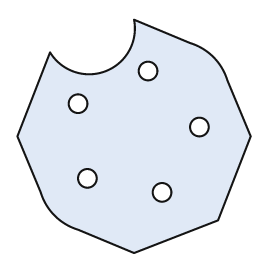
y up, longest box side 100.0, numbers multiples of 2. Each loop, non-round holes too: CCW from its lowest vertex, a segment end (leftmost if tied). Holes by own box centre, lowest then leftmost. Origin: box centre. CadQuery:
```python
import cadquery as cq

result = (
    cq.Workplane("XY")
    .moveTo(0.0, -50.0)
    .lineTo(36.0, -36.0)
    .lineTo(50.0, 0.0)
    .lineTo(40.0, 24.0)
    .threePointArc((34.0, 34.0), (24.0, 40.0))
    .lineTo(0.0, 50.0)
    .threePointArc((-12.0, 28.0), (-36.0, 36.0))
    .lineTo(-50.0, 0.0)
    .lineTo(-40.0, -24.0)
    .threePointArc((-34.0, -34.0), (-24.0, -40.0))
    .close()
    .moveTo(12.0, -24.0)
    .circle(4.0)
    .moveTo(-20.0, -18.0)
    .circle(4.0)
    .moveTo(28.0, 4.0)
    .circle(4.0)
    .moveTo(-24.0, 14.0)
    .circle(4.0)
    .moveTo(6.0, 28.0)
    .circle(4.0)
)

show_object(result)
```